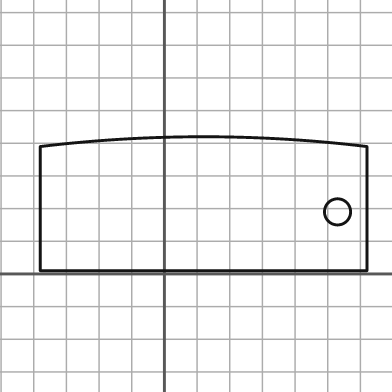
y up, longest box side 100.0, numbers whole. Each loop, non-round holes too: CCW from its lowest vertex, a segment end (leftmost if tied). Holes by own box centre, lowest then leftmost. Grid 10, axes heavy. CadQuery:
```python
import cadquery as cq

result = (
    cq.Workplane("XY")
    .moveTo(-38.0, 1.0)
    .lineTo(62.0, 1.0)
    .lineTo(62.0, 39.0)
    .threePointArc((12.0, 42.0), (-38.0, 39.0))
    .close()
    .moveTo(53.0, 19.0)
    .circle(4.0)
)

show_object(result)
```